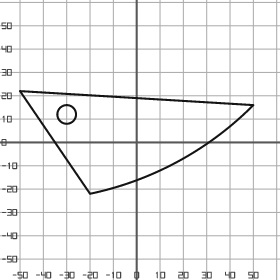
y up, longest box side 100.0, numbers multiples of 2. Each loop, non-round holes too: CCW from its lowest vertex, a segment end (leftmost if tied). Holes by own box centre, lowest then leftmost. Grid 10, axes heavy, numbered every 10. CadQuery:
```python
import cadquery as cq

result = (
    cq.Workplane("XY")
    .moveTo(-20.0, -22.0)
    .threePointArc((18.0, -8.0), (50.0, 16.0))
    .lineTo(-50.0, 22.0)
    .close()
    .moveTo(-30.0, 12.0)
    .circle(4.0)
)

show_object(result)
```